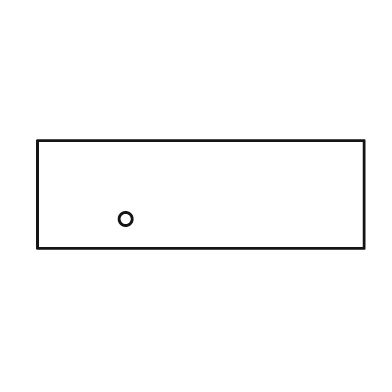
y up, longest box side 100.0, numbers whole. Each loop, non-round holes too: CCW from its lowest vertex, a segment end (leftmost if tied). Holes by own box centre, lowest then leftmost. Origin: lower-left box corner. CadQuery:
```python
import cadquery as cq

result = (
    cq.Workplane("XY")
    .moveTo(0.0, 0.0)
    .lineTo(100.0, 0.0)
    .lineTo(100.0, 33.0)
    .lineTo(0.0, 33.0)
    .close()
    .moveTo(27.0, 9.0)
    .circle(2.0)
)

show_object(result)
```